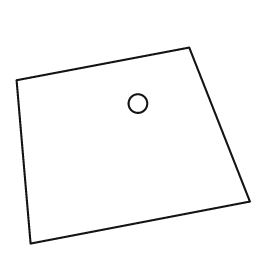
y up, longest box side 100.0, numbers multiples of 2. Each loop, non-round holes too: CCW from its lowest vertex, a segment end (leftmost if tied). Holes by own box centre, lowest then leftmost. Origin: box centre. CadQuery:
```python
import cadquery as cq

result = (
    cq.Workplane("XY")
    .moveTo(-44.0, -42.0)
    .lineTo(50.0, -24.0)
    .lineTo(24.0, 42.0)
    .lineTo(-50.0, 28.0)
    .close()
    .moveTo(2.0, 18.0)
    .circle(4.0)
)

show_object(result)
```